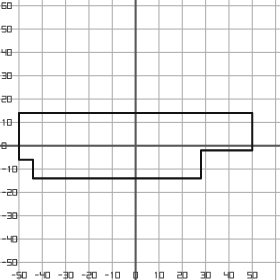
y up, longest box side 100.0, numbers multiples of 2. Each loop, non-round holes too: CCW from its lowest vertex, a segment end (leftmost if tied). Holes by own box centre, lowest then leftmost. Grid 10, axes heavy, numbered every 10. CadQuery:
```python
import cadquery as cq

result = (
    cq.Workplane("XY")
    .moveTo(-44.0, -14.0)
    .lineTo(28.0, -14.0)
    .lineTo(28.0, -2.0)
    .lineTo(50.0, -2.0)
    .lineTo(50.0, 14.0)
    .lineTo(-50.0, 14.0)
    .lineTo(-50.0, -6.0)
    .lineTo(-44.0, -6.0)
    .close()
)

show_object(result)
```